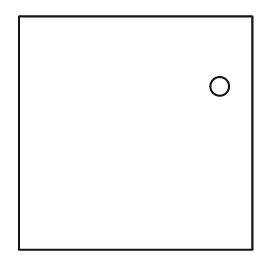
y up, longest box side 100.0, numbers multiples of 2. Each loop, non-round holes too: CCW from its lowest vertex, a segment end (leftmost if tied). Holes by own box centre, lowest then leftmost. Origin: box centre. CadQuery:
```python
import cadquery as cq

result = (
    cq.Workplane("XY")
    .moveTo(-50.0, -50.0)
    .lineTo(50.0, -50.0)
    .lineTo(50.0, 50.0)
    .lineTo(-50.0, 50.0)
    .close()
    .moveTo(36.0, 20.0)
    .circle(4.0)
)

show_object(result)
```